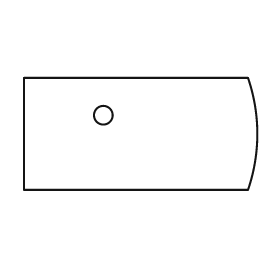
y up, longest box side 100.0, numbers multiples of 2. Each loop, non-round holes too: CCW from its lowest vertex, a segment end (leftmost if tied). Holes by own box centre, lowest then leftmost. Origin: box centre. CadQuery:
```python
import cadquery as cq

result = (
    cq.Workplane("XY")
    .moveTo(-50.0, -24.0)
    .lineTo(46.0, -24.0)
    .threePointArc((50.0, 0.0), (46.0, 24.0))
    .lineTo(-50.0, 24.0)
    .close()
    .moveTo(-16.0, 8.0)
    .circle(4.0)
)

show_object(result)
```